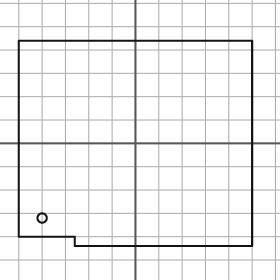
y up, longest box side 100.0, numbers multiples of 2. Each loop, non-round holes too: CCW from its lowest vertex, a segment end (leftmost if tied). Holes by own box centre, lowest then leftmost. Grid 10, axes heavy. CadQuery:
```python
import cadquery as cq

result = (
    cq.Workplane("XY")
    .moveTo(-26.0, -44.0)
    .lineTo(50.0, -44.0)
    .lineTo(50.0, 44.0)
    .lineTo(-50.0, 44.0)
    .lineTo(-50.0, -40.0)
    .lineTo(-26.0, -40.0)
    .close()
    .moveTo(-40.0, -32.0)
    .circle(2.0)
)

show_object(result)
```